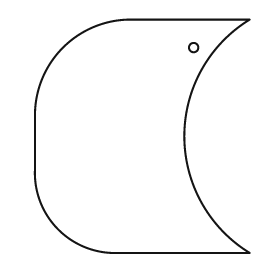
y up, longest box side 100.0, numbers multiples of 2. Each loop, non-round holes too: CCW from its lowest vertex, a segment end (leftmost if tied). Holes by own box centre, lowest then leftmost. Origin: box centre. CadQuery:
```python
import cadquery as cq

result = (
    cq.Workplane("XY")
    .moveTo(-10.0, -50.0)
    .lineTo(46.0, -50.0)
    .threePointArc((18.0, 0.0), (46.0, 50.0))
    .lineTo(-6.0, 50.0)
    .threePointArc((-34.0, 38.0), (-46.0, 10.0))
    .lineTo(-46.0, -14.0)
    .threePointArc((-36.0, -40.0), (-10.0, -50.0))
    .close()
    .moveTo(22.0, 38.0)
    .circle(2.0)
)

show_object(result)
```